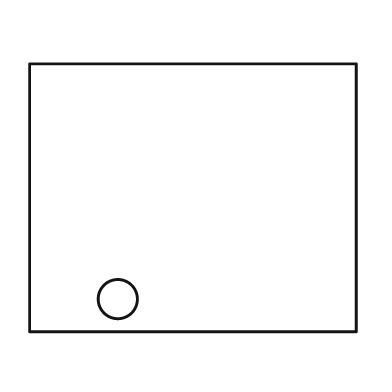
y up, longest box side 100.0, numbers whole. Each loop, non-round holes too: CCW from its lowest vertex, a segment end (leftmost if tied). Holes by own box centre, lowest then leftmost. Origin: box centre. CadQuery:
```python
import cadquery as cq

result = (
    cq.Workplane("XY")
    .moveTo(-50.0, -41.0)
    .lineTo(50.0, -41.0)
    .lineTo(50.0, 41.0)
    .lineTo(-50.0, 41.0)
    .close()
    .moveTo(-23.0, -31.0)
    .circle(6.0)
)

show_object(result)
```